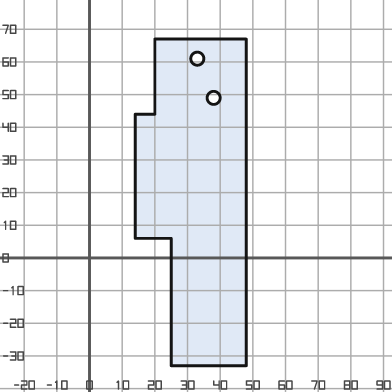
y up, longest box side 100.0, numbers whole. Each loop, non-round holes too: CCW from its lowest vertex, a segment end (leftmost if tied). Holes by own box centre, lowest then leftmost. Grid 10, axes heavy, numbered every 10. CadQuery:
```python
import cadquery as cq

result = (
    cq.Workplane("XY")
    .moveTo(25.0, -33.0)
    .lineTo(48.0, -33.0)
    .lineTo(48.0, 67.0)
    .lineTo(20.0, 67.0)
    .lineTo(20.0, 44.0)
    .lineTo(14.0, 44.0)
    .lineTo(14.0, 6.0)
    .lineTo(25.0, 6.0)
    .close()
    .moveTo(38.0, 49.0)
    .circle(2.0)
    .moveTo(33.0, 61.0)
    .circle(2.0)
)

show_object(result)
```